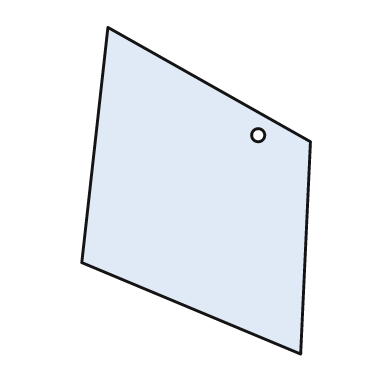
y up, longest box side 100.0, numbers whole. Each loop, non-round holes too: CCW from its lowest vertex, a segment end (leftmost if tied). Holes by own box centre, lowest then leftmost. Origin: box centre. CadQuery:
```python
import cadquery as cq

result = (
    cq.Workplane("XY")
    .moveTo(32.0, -50.0)
    .lineTo(35.0, 15.0)
    .lineTo(-27.0, 50.0)
    .lineTo(-35.0, -22.0)
    .close()
    .moveTo(19.0, 17.0)
    .circle(2.0)
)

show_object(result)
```